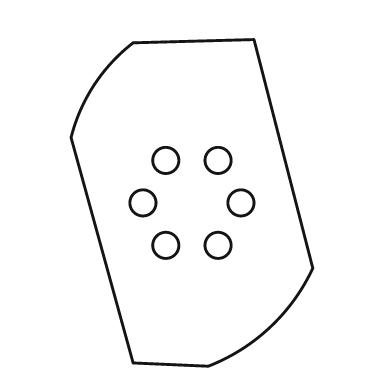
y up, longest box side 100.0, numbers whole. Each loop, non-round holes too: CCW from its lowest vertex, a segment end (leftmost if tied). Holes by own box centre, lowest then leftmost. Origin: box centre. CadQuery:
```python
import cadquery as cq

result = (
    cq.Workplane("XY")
    .moveTo(5.0, -50.0)
    .threePointArc((24.0, -38.0), (37.0, -20.0))
    .lineTo(19.0, 50.0)
    .lineTo(-18.0, 49.0)
    .threePointArc((-30.0, 36.0), (-37.0, 20.0))
    .lineTo(-18.0, -49.0)
    .close()
    .moveTo(-8.0, -13.0)
    .circle(4.0)
    .moveTo(8.0, -13.0)
    .circle(4.0)
    .moveTo(-15.0, 0.0)
    .circle(4.0)
    .moveTo(15.0, 0.0)
    .circle(4.0)
    .moveTo(-8.0, 13.0)
    .circle(4.0)
    .moveTo(8.0, 13.0)
    .circle(4.0)
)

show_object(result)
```